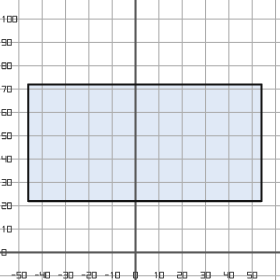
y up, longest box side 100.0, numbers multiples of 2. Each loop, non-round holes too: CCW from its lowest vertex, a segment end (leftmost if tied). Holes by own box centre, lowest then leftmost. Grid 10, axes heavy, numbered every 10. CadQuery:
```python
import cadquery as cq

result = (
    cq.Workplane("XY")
    .moveTo(-46.0, 22.0)
    .lineTo(54.0, 22.0)
    .lineTo(54.0, 72.0)
    .lineTo(-46.0, 72.0)
    .close()
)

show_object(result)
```